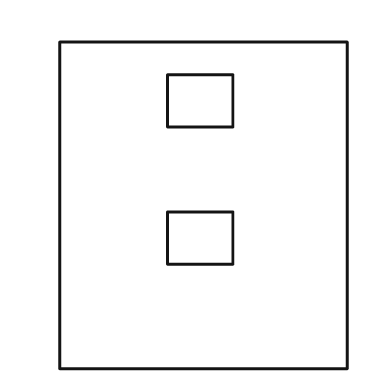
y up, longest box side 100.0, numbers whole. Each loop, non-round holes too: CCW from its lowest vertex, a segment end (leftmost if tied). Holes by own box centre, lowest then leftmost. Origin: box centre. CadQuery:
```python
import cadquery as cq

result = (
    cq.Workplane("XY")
    .moveTo(-44.0, -50.0)
    .lineTo(44.0, -50.0)
    .lineTo(44.0, 50.0)
    .lineTo(-44.0, 50.0)
    .close()
    .moveTo(-11.0, -18.0)
    .lineTo(9.0, -18.0)
    .lineTo(9.0, -2.0)
    .lineTo(-11.0, -2.0)
    .close()
    .moveTo(-11.0, 24.0)
    .lineTo(9.0, 24.0)
    .lineTo(9.0, 40.0)
    .lineTo(-11.0, 40.0)
    .close()
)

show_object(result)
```